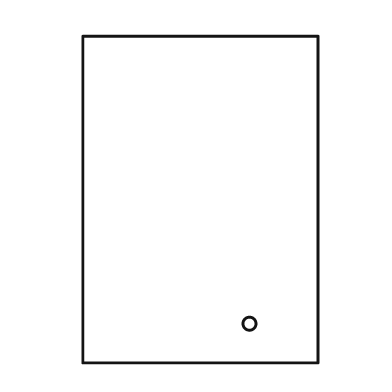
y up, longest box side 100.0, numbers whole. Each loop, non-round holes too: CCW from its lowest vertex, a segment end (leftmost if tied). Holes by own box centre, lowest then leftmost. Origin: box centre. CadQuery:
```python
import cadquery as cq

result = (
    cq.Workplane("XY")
    .moveTo(-36.0, -50.0)
    .lineTo(36.0, -50.0)
    .lineTo(36.0, 50.0)
    .lineTo(-36.0, 50.0)
    .close()
    .moveTo(15.0, -38.0)
    .circle(2.0)
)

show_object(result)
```